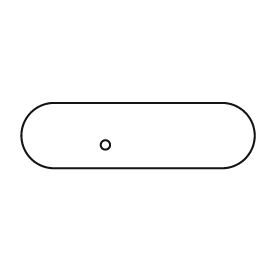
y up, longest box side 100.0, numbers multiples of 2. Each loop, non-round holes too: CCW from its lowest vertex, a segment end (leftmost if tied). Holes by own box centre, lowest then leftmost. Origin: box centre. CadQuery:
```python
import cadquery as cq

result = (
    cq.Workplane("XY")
    .moveTo(-36.0, -14.0)
    .lineTo(36.0, -14.0)
    .threePointArc((50.0, 0.0), (36.0, 14.0))
    .lineTo(-36.0, 14.0)
    .threePointArc((-50.0, 0.0), (-36.0, -14.0))
    .close()
    .moveTo(-14.0, -4.0)
    .circle(2.0)
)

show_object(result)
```